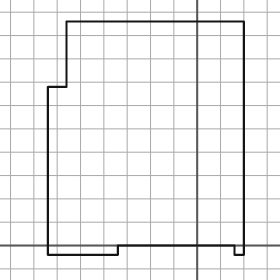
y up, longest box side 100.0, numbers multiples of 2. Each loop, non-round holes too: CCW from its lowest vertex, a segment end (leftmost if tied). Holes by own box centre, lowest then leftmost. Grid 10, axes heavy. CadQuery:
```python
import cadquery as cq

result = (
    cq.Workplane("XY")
    .moveTo(-64.0, -4.0)
    .lineTo(-34.0, -4.0)
    .lineTo(-34.0, 0.0)
    .lineTo(16.0, 0.0)
    .lineTo(16.0, -4.0)
    .lineTo(20.0, -4.0)
    .lineTo(20.0, 96.0)
    .lineTo(-56.0, 96.0)
    .lineTo(-56.0, 68.0)
    .lineTo(-64.0, 68.0)
    .close()
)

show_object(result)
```